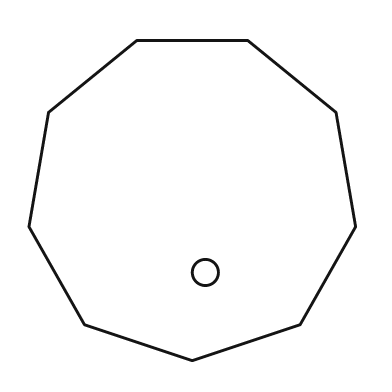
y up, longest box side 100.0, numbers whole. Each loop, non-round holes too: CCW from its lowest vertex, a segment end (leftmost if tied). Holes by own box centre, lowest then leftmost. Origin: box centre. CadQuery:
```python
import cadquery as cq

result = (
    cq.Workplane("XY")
    .moveTo(0.0, -49.0)
    .lineTo(33.0, -38.0)
    .lineTo(50.0, -8.0)
    .lineTo(44.0, 27.0)
    .lineTo(17.0, 49.0)
    .lineTo(-17.0, 49.0)
    .lineTo(-44.0, 27.0)
    .lineTo(-50.0, -8.0)
    .lineTo(-33.0, -38.0)
    .close()
    .moveTo(4.0, -22.0)
    .circle(4.0)
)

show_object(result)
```